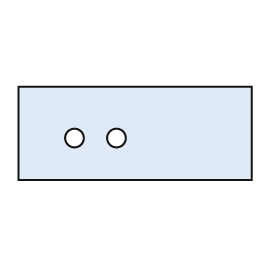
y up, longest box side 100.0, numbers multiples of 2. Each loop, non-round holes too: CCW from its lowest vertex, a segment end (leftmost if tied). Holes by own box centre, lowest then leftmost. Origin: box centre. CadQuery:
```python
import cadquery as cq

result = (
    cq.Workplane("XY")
    .moveTo(-50.0, -20.0)
    .lineTo(50.0, -20.0)
    .lineTo(50.0, 20.0)
    .lineTo(-50.0, 20.0)
    .close()
    .moveTo(-26.0, -2.0)
    .circle(4.0)
    .moveTo(-8.0, -2.0)
    .circle(4.0)
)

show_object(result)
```